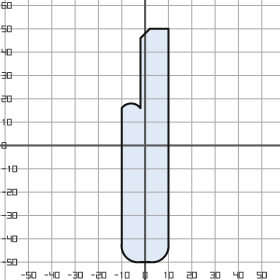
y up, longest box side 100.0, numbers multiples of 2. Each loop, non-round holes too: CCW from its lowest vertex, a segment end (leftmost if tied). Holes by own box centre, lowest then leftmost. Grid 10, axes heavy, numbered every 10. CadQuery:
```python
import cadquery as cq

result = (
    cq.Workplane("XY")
    .moveTo(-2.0, -50.0)
    .lineTo(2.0, -50.0)
    .threePointArc((8.0, -48.0), (10.0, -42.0))
    .lineTo(10.0, 50.0)
    .lineTo(2.0, 50.0)
    .lineTo(-2.0, 46.0)
    .lineTo(-2.0, 16.0)
    .threePointArc((-6.0, 18.0), (-10.0, 16.0))
    .lineTo(-10.0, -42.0)
    .threePointArc((-8.0, -48.0), (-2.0, -50.0))
    .close()
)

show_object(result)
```